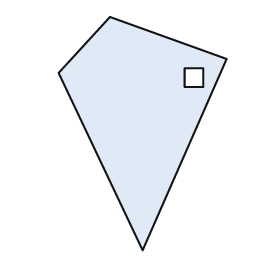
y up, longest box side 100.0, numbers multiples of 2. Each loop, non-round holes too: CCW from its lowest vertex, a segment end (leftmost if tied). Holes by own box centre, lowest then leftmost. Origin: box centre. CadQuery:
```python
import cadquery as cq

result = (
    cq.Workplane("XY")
    .moveTo(0.0, -50.0)
    .lineTo(36.0, 32.0)
    .lineTo(-14.0, 50.0)
    .lineTo(-36.0, 26.0)
    .close()
    .moveTo(18.0, 20.0)
    .lineTo(26.0, 20.0)
    .lineTo(26.0, 28.0)
    .lineTo(18.0, 28.0)
    .close()
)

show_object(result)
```